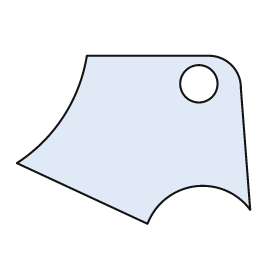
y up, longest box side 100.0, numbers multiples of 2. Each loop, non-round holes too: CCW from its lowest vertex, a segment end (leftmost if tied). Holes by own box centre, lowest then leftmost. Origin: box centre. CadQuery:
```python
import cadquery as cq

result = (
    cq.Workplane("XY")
    .moveTo(6.0, -36.0)
    .threePointArc((26.0, -20.0), (50.0, -30.0))
    .lineTo(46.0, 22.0)
    .threePointArc((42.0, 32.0), (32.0, 36.0))
    .lineTo(-20.0, 36.0)
    .threePointArc((-30.0, 10.0), (-50.0, -10.0))
    .close()
    .moveTo(28.0, 24.0)
    .circle(8.0)
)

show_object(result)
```